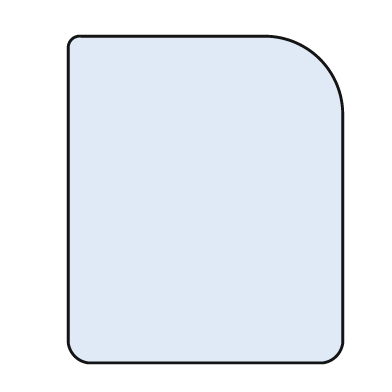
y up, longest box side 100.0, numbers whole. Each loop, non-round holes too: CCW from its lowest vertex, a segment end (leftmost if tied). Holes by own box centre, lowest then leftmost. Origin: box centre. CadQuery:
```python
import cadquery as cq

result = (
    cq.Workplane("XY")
    .moveTo(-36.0, -50.0)
    .lineTo(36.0, -50.0)
    .threePointArc((40.0, -48.0), (42.0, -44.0))
    .lineTo(42.0, 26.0)
    .threePointArc((35.0, 43.0), (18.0, 50.0))
    .lineTo(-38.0, 50.0)
    .threePointArc((-41.0, 49.0), (-42.0, 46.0))
    .lineTo(-42.0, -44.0)
    .threePointArc((-40.0, -48.0), (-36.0, -50.0))
    .close()
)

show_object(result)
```